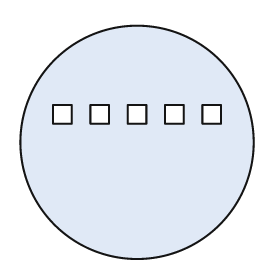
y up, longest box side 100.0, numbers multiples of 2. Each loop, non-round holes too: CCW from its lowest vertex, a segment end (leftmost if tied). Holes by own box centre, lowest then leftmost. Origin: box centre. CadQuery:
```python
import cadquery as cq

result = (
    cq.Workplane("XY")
    .moveTo(0.0, 0.0)
    .circle(50.0)
    .moveTo(-36.0, 8.0)
    .lineTo(-28.0, 8.0)
    .lineTo(-28.0, 16.0)
    .lineTo(-36.0, 16.0)
    .close()
    .moveTo(-20.0, 8.0)
    .lineTo(-12.0, 8.0)
    .lineTo(-12.0, 16.0)
    .lineTo(-20.0, 16.0)
    .close()
    .moveTo(-4.0, 8.0)
    .lineTo(4.0, 8.0)
    .lineTo(4.0, 16.0)
    .lineTo(-4.0, 16.0)
    .close()
    .moveTo(12.0, 8.0)
    .lineTo(20.0, 8.0)
    .lineTo(20.0, 16.0)
    .lineTo(12.0, 16.0)
    .close()
    .moveTo(28.0, 8.0)
    .lineTo(36.0, 8.0)
    .lineTo(36.0, 16.0)
    .lineTo(28.0, 16.0)
    .close()
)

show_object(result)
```